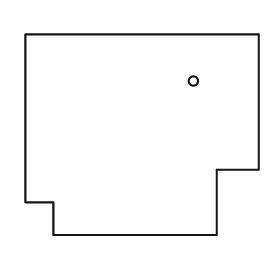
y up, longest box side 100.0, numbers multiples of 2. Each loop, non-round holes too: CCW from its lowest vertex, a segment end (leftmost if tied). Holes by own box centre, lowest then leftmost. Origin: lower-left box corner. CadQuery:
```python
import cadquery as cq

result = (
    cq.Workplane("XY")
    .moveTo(12.0, 0.0)
    .lineTo(82.0, 0.0)
    .lineTo(82.0, 28.0)
    .lineTo(100.0, 28.0)
    .lineTo(100.0, 86.0)
    .lineTo(0.0, 86.0)
    .lineTo(0.0, 14.0)
    .lineTo(12.0, 14.0)
    .close()
    .moveTo(72.0, 66.0)
    .circle(2.0)
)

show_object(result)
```